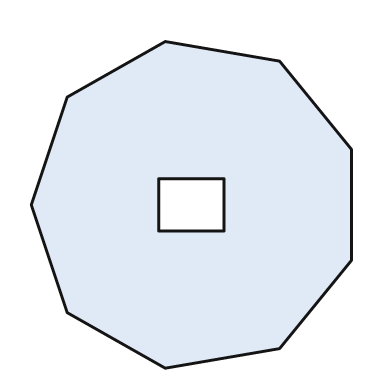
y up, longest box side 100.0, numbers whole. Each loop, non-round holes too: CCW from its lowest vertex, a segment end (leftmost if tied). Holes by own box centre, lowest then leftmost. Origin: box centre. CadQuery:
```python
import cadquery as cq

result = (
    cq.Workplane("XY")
    .moveTo(-8.0, -50.0)
    .lineTo(27.0, -44.0)
    .lineTo(49.0, -17.0)
    .lineTo(49.0, 17.0)
    .lineTo(27.0, 44.0)
    .lineTo(-8.0, 50.0)
    .lineTo(-38.0, 33.0)
    .lineTo(-49.0, 0.0)
    .lineTo(-38.0, -33.0)
    .close()
    .moveTo(-10.0, -8.0)
    .lineTo(10.0, -8.0)
    .lineTo(10.0, 8.0)
    .lineTo(-10.0, 8.0)
    .close()
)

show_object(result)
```